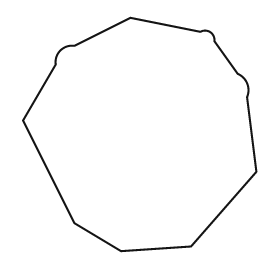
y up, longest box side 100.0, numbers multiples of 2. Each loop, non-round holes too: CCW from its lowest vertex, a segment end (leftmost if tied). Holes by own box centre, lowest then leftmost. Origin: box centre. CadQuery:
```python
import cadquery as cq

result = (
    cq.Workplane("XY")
    .moveTo(-8.0, -50.0)
    .lineTo(22.0, -48.0)
    .lineTo(50.0, -16.0)
    .lineTo(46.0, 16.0)
    .threePointArc((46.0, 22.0), (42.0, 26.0))
    .lineTo(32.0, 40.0)
    .threePointArc((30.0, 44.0), (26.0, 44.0))
    .lineTo(-4.0, 50.0)
    .lineTo(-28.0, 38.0)
    .threePointArc((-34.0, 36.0), (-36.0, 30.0))
    .lineTo(-50.0, 6.0)
    .lineTo(-28.0, -38.0)
    .close()
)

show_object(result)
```